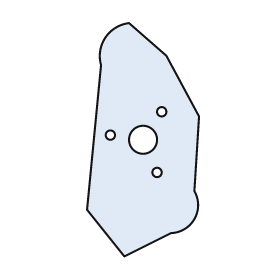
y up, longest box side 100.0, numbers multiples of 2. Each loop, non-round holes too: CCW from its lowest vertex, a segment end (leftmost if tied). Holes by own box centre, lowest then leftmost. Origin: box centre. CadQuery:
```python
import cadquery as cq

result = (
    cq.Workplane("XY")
    .moveTo(-8.0, -50.0)
    .lineTo(12.0, -40.0)
    .threePointArc((22.0, -34.0), (22.0, -22.0))
    .lineTo(24.0, 10.0)
    .lineTo(10.0, 36.0)
    .lineTo(-6.0, 50.0)
    .threePointArc((-16.0, 44.0), (-18.0, 32.0))
    .lineTo(-24.0, -30.0)
    .close()
    .moveTo(6.0, -14.0)
    .circle(2.0)
    .moveTo(0.0, 0.0)
    .circle(6.0)
    .moveTo(-14.0, 2.0)
    .circle(2.0)
    .moveTo(8.0, 12.0)
    .circle(2.0)
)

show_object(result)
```